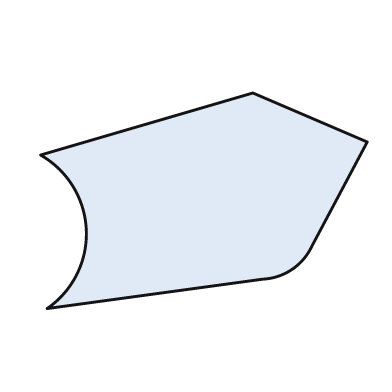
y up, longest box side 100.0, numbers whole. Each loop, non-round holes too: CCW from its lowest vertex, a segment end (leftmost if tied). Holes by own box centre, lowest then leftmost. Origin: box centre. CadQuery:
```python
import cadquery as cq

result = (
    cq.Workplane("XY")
    .moveTo(-48.0, -33.0)
    .lineTo(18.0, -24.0)
    .threePointArc((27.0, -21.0), (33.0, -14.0))
    .lineTo(50.0, 18.0)
    .lineTo(15.0, 33.0)
    .lineTo(-50.0, 14.0)
    .threePointArc((-36.0, -9.0), (-48.0, -33.0))
    .close()
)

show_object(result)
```